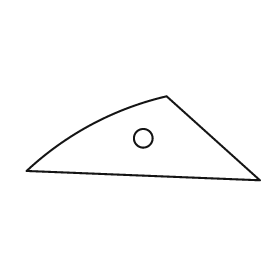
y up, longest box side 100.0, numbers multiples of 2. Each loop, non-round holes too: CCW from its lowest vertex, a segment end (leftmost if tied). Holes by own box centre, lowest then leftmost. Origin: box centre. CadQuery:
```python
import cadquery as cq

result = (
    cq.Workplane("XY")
    .moveTo(50.0, -18.0)
    .lineTo(10.0, 18.0)
    .threePointArc((-22.0, 6.0), (-50.0, -14.0))
    .close()
    .moveTo(0.0, 0.0)
    .circle(4.0)
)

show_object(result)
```